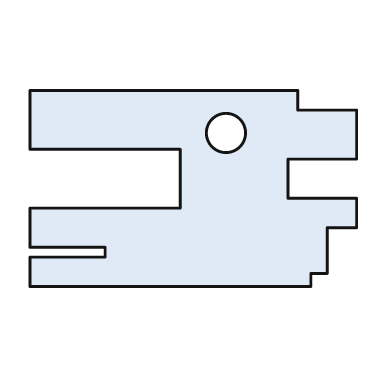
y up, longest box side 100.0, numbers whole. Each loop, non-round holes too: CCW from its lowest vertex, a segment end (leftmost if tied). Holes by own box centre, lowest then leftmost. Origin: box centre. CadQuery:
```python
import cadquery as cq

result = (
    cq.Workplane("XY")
    .moveTo(-50.0, -30.0)
    .lineTo(36.0, -30.0)
    .lineTo(36.0, -26.0)
    .lineTo(41.0, -26.0)
    .lineTo(41.0, -12.0)
    .lineTo(50.0, -12.0)
    .lineTo(50.0, -3.0)
    .lineTo(29.0, -3.0)
    .lineTo(29.0, 9.0)
    .lineTo(50.0, 9.0)
    .lineTo(50.0, 24.0)
    .lineTo(32.0, 24.0)
    .lineTo(32.0, 30.0)
    .lineTo(-50.0, 30.0)
    .lineTo(-50.0, 12.0)
    .lineTo(-4.0, 12.0)
    .lineTo(-4.0, -6.0)
    .lineTo(-50.0, -6.0)
    .lineTo(-50.0, -18.0)
    .lineTo(-27.0, -18.0)
    .lineTo(-27.0, -21.0)
    .lineTo(-50.0, -21.0)
    .close()
    .moveTo(10.0, 17.0)
    .circle(6.0)
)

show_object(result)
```